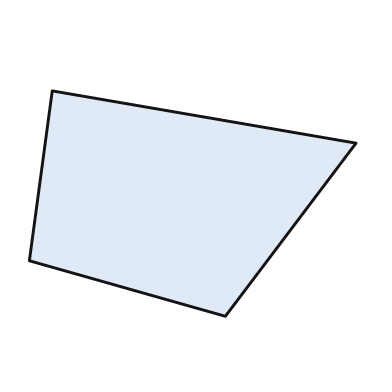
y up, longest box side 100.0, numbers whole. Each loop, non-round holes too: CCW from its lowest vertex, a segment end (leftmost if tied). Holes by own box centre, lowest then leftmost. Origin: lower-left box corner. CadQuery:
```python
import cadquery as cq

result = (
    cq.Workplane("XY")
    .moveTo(60.0, 0.0)
    .lineTo(100.0, 53.0)
    .lineTo(7.0, 69.0)
    .lineTo(0.0, 17.0)
    .close()
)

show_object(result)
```